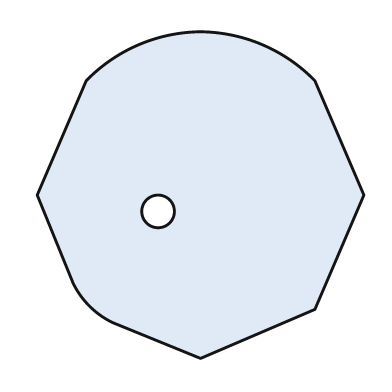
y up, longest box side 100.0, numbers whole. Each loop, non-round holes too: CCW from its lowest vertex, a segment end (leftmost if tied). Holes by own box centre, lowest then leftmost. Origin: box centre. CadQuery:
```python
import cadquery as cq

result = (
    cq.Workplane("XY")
    .moveTo(0.0, -50.0)
    .lineTo(35.0, -35.0)
    .lineTo(50.0, 0.0)
    .lineTo(35.0, 35.0)
    .threePointArc((19.0, 46.0), (0.0, 50.0))
    .threePointArc((-19.0, 46.0), (-35.0, 35.0))
    .lineTo(-50.0, 0.0)
    .lineTo(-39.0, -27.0)
    .threePointArc((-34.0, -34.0), (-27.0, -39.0))
    .close()
    .moveTo(-13.0, -5.0)
    .circle(5.0)
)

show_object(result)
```